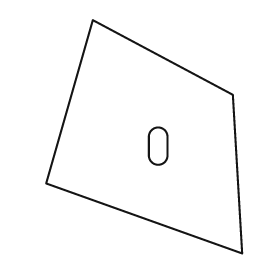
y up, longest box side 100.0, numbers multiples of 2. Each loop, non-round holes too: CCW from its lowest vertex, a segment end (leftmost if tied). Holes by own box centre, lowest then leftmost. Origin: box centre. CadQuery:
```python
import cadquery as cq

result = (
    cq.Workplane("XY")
    .moveTo(42.0, -50.0)
    .lineTo(38.0, 18.0)
    .lineTo(-22.0, 50.0)
    .lineTo(-42.0, -20.0)
    .close()
    .moveTo(2.0, -8.0)
    .threePointArc((6.0, -12.0), (10.0, -8.0))
    .lineTo(10.0, 0.0)
    .threePointArc((6.0, 4.0), (2.0, 0.0))
    .close()
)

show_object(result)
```